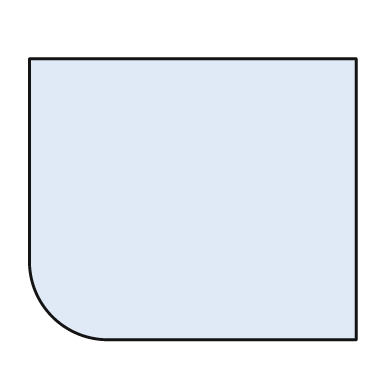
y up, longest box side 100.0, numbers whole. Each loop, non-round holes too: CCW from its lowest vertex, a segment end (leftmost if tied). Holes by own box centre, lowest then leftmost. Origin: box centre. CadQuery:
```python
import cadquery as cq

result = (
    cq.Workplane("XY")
    .moveTo(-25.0, -43.0)
    .lineTo(50.0, -43.0)
    .lineTo(50.0, 43.0)
    .lineTo(-50.0, 43.0)
    .lineTo(-50.0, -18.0)
    .threePointArc((-43.0, -36.0), (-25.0, -43.0))
    .close()
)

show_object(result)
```